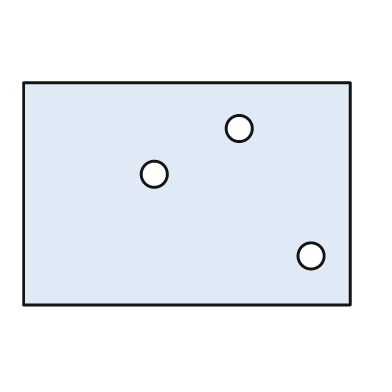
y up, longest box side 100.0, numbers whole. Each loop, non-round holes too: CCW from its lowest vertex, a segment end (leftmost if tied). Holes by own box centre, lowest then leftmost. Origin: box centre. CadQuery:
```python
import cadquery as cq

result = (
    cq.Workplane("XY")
    .moveTo(-50.0, -34.0)
    .lineTo(50.0, -34.0)
    .lineTo(50.0, 34.0)
    .lineTo(-50.0, 34.0)
    .close()
    .moveTo(38.0, -19.0)
    .circle(4.0)
    .moveTo(-10.0, 6.0)
    .circle(4.0)
    .moveTo(16.0, 20.0)
    .circle(4.0)
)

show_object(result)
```